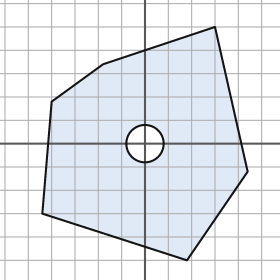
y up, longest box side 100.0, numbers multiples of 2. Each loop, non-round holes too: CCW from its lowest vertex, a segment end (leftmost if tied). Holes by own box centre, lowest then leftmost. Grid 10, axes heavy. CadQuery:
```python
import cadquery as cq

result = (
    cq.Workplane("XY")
    .moveTo(18.0, -50.0)
    .lineTo(44.0, -12.0)
    .lineTo(30.0, 50.0)
    .lineTo(-18.0, 34.0)
    .lineTo(-40.0, 18.0)
    .lineTo(-44.0, -30.0)
    .close()
    .moveTo(0.0, 0.0)
    .circle(8.0)
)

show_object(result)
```